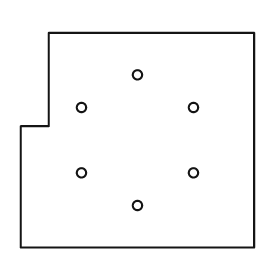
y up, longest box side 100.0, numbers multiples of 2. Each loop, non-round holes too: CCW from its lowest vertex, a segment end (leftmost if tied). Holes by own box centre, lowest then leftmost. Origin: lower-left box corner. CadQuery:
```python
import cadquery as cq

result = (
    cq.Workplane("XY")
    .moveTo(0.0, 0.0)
    .lineTo(100.0, 0.0)
    .lineTo(100.0, 92.0)
    .lineTo(12.0, 92.0)
    .lineTo(12.0, 52.0)
    .lineTo(0.0, 52.0)
    .close()
    .moveTo(50.0, 18.0)
    .circle(2.0)
    .moveTo(26.0, 32.0)
    .circle(2.0)
    .moveTo(74.0, 32.0)
    .circle(2.0)
    .moveTo(26.0, 60.0)
    .circle(2.0)
    .moveTo(74.0, 60.0)
    .circle(2.0)
    .moveTo(50.0, 74.0)
    .circle(2.0)
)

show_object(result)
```